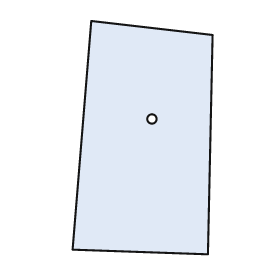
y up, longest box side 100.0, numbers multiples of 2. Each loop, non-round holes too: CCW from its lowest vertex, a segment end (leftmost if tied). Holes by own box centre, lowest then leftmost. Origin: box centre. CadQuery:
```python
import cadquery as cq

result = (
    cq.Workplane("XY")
    .moveTo(28.0, -50.0)
    .lineTo(30.0, 44.0)
    .lineTo(-22.0, 50.0)
    .lineTo(-30.0, -48.0)
    .close()
    .moveTo(4.0, 8.0)
    .circle(2.0)
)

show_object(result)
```